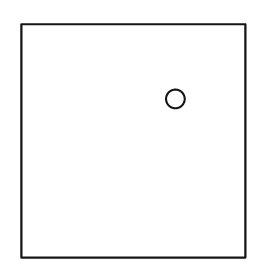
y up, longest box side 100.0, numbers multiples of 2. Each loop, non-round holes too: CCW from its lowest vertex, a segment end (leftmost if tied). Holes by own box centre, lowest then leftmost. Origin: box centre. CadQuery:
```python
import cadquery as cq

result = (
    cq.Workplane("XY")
    .moveTo(-48.0, -50.0)
    .lineTo(48.0, -50.0)
    .lineTo(48.0, 50.0)
    .lineTo(-48.0, 50.0)
    .close()
    .moveTo(18.0, 18.0)
    .circle(4.0)
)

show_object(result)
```